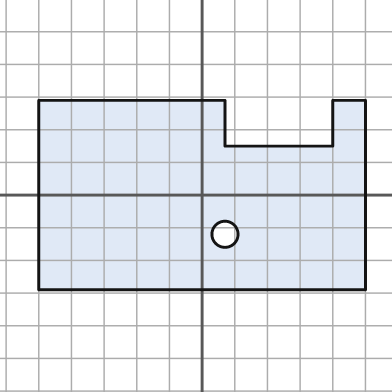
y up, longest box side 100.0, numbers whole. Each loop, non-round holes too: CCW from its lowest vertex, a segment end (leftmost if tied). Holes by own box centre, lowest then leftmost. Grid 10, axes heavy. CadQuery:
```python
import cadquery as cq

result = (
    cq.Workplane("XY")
    .moveTo(-50.0, -29.0)
    .lineTo(50.0, -29.0)
    .lineTo(50.0, 29.0)
    .lineTo(40.0, 29.0)
    .lineTo(40.0, 15.0)
    .lineTo(7.0, 15.0)
    .lineTo(7.0, 29.0)
    .lineTo(-50.0, 29.0)
    .close()
    .moveTo(7.0, -12.0)
    .circle(4.0)
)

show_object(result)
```